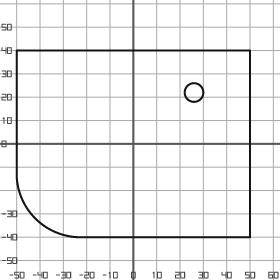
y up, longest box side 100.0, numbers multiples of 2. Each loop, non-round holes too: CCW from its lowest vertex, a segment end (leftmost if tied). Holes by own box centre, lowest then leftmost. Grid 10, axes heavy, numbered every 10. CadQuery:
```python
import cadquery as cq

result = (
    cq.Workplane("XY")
    .moveTo(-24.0, -40.0)
    .lineTo(50.0, -40.0)
    .lineTo(50.0, 40.0)
    .lineTo(-50.0, 40.0)
    .lineTo(-50.0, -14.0)
    .threePointArc((-42.0, -32.0), (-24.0, -40.0))
    .close()
    .moveTo(26.0, 22.0)
    .circle(4.0)
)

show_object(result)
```